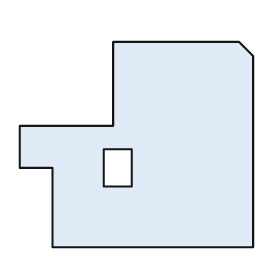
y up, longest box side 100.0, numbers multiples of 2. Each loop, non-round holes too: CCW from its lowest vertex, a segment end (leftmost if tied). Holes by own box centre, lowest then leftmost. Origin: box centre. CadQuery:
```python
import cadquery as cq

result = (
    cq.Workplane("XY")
    .moveTo(-36.0, -44.0)
    .lineTo(50.0, -44.0)
    .lineTo(50.0, 38.0)
    .lineTo(44.0, 44.0)
    .lineTo(-10.0, 44.0)
    .lineTo(-10.0, 8.0)
    .lineTo(-50.0, 8.0)
    .lineTo(-50.0, -10.0)
    .lineTo(-36.0, -10.0)
    .close()
    .moveTo(-14.0, -18.0)
    .lineTo(-2.0, -18.0)
    .lineTo(-2.0, -2.0)
    .lineTo(-14.0, -2.0)
    .close()
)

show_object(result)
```